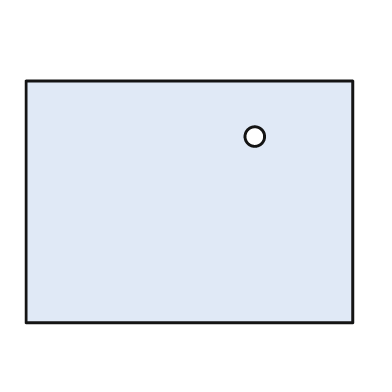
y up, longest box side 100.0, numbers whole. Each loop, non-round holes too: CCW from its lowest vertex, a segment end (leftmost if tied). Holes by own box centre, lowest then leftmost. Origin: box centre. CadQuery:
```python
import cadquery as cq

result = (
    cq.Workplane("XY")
    .moveTo(-50.0, -37.0)
    .lineTo(50.0, -37.0)
    .lineTo(50.0, 37.0)
    .lineTo(-50.0, 37.0)
    .close()
    .moveTo(20.0, 20.0)
    .circle(3.0)
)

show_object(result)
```